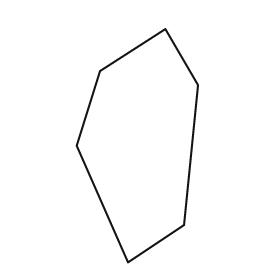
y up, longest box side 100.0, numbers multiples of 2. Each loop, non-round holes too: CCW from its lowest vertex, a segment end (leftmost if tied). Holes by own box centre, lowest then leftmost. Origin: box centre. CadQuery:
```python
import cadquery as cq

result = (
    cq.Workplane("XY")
    .moveTo(-4.0, -50.0)
    .lineTo(20.0, -34.0)
    .lineTo(26.0, 26.0)
    .lineTo(12.0, 50.0)
    .lineTo(-16.0, 32.0)
    .lineTo(-26.0, 0.0)
    .close()
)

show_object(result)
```